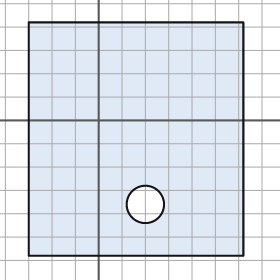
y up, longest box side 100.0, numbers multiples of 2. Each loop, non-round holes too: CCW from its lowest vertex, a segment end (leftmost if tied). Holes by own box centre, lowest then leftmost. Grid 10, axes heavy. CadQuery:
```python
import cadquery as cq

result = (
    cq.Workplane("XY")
    .moveTo(-30.0, -58.0)
    .lineTo(62.0, -58.0)
    .lineTo(62.0, 42.0)
    .lineTo(-30.0, 42.0)
    .close()
    .moveTo(20.0, -36.0)
    .circle(8.0)
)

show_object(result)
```